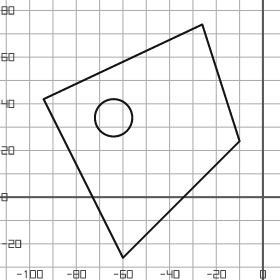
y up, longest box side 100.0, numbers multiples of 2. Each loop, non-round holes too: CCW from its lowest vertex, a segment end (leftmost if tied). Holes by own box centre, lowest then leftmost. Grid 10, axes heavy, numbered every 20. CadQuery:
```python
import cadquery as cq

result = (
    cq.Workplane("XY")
    .moveTo(-60.0, -26.0)
    .lineTo(-10.0, 24.0)
    .lineTo(-26.0, 74.0)
    .lineTo(-94.0, 42.0)
    .close()
    .moveTo(-64.0, 34.0)
    .circle(8.0)
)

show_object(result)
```